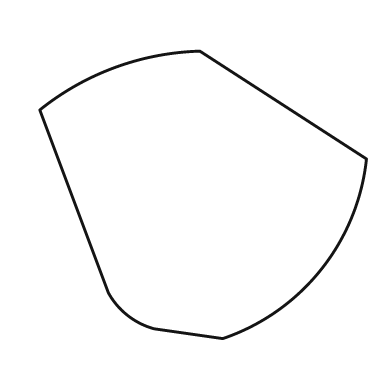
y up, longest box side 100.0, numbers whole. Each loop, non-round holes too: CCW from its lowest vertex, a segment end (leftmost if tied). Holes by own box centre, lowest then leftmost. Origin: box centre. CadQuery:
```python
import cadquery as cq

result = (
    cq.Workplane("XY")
    .moveTo(6.0, -44.0)
    .threePointArc((36.0, -23.0), (50.0, 11.0))
    .lineTo(-1.0, 44.0)
    .threePointArc((-27.0, 39.0), (-50.0, 26.0))
    .lineTo(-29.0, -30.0)
    .threePointArc((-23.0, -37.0), (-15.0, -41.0))
    .close()
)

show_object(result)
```